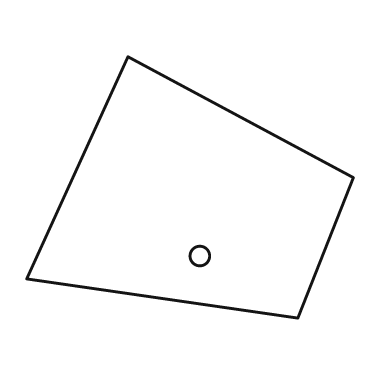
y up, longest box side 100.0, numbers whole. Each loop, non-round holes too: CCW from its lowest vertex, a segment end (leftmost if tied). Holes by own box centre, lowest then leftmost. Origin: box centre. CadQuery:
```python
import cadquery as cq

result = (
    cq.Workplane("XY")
    .moveTo(33.0, -40.0)
    .lineTo(50.0, 3.0)
    .lineTo(-19.0, 40.0)
    .lineTo(-50.0, -28.0)
    .close()
    .moveTo(3.0, -21.0)
    .circle(3.0)
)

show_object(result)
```